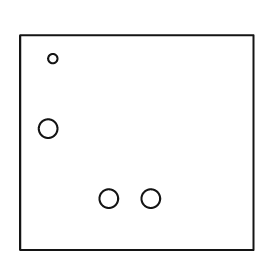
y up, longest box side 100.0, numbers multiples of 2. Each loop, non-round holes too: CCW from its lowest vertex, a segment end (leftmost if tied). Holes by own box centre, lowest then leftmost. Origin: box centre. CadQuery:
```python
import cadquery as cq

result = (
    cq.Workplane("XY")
    .moveTo(-50.0, -46.0)
    .lineTo(50.0, -46.0)
    .lineTo(50.0, 46.0)
    .lineTo(-50.0, 46.0)
    .close()
    .moveTo(-12.0, -24.0)
    .circle(4.0)
    .moveTo(6.0, -24.0)
    .circle(4.0)
    .moveTo(-38.0, 6.0)
    .circle(4.0)
    .moveTo(-36.0, 36.0)
    .circle(2.0)
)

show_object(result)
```